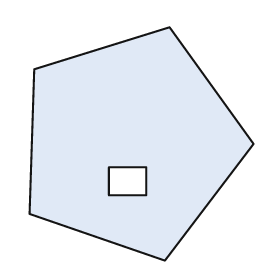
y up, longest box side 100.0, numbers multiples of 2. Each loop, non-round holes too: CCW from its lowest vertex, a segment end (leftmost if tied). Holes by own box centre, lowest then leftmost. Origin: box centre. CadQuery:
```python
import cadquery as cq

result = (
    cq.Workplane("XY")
    .moveTo(10.0, -50.0)
    .lineTo(48.0, 0.0)
    .lineTo(12.0, 50.0)
    .lineTo(-46.0, 32.0)
    .lineTo(-48.0, -30.0)
    .close()
    .moveTo(-14.0, -22.0)
    .lineTo(2.0, -22.0)
    .lineTo(2.0, -10.0)
    .lineTo(-14.0, -10.0)
    .close()
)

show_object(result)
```